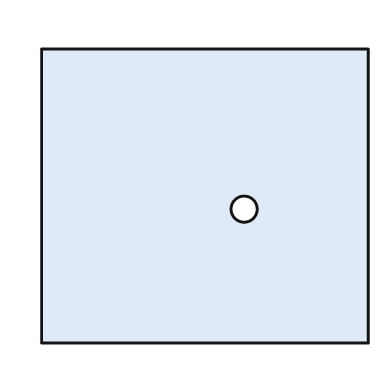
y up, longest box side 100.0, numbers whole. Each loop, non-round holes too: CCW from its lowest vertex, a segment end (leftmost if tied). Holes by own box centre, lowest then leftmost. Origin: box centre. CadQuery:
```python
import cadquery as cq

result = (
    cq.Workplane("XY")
    .moveTo(-50.0, -45.0)
    .lineTo(50.0, -45.0)
    .lineTo(50.0, 45.0)
    .lineTo(-50.0, 45.0)
    .close()
    .moveTo(12.0, -4.0)
    .circle(4.0)
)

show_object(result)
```